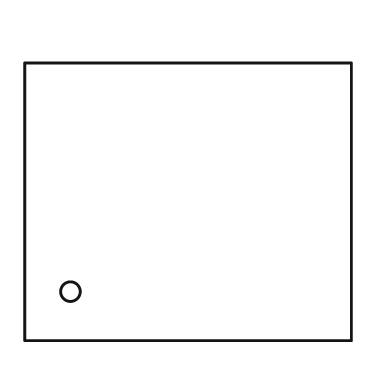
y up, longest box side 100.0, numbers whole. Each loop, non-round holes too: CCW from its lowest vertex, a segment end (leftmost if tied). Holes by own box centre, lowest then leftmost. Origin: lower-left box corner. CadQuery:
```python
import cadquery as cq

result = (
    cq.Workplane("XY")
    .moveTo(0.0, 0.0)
    .lineTo(100.0, 0.0)
    .lineTo(100.0, 85.0)
    .lineTo(0.0, 85.0)
    .close()
    .moveTo(14.0, 15.0)
    .circle(3.0)
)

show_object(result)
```